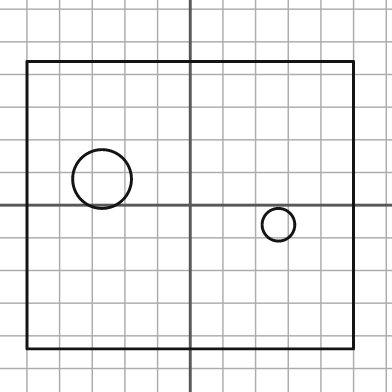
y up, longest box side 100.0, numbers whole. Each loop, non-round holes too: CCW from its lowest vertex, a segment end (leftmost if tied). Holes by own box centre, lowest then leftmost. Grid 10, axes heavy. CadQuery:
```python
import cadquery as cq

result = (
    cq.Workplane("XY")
    .moveTo(-50.0, -44.0)
    .lineTo(50.0, -44.0)
    .lineTo(50.0, 44.0)
    .lineTo(-50.0, 44.0)
    .close()
    .moveTo(27.0, -6.0)
    .circle(5.0)
    .moveTo(-27.0, 8.0)
    .circle(9.0)
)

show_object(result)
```